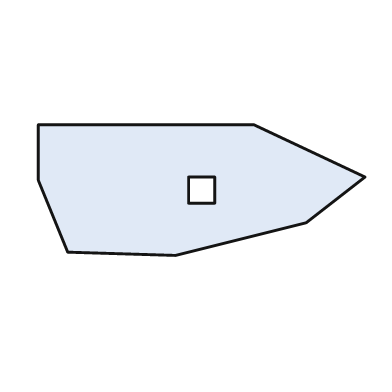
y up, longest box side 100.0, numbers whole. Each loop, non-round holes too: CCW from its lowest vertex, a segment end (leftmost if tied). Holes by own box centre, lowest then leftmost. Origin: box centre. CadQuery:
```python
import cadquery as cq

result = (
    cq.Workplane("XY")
    .moveTo(-8.0, -20.0)
    .lineTo(32.0, -10.0)
    .lineTo(50.0, 4.0)
    .lineTo(16.0, 20.0)
    .lineTo(-50.0, 20.0)
    .lineTo(-50.0, 3.0)
    .lineTo(-41.0, -19.0)
    .close()
    .moveTo(-4.0, -4.0)
    .lineTo(4.0, -4.0)
    .lineTo(4.0, 4.0)
    .lineTo(-4.0, 4.0)
    .close()
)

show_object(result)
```